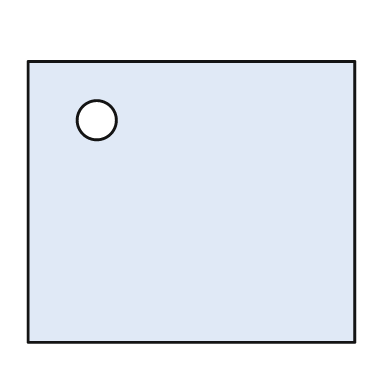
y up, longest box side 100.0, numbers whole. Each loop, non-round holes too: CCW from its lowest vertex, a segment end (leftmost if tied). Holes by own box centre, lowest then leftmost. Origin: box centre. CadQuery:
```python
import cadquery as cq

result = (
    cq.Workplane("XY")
    .moveTo(-50.0, -43.0)
    .lineTo(50.0, -43.0)
    .lineTo(50.0, 43.0)
    .lineTo(-50.0, 43.0)
    .close()
    .moveTo(-29.0, 25.0)
    .circle(6.0)
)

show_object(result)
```